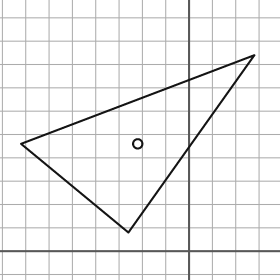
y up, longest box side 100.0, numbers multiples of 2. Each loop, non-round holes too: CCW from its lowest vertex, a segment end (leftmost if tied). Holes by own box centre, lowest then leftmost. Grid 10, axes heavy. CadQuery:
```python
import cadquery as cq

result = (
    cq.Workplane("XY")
    .moveTo(-26.0, 8.0)
    .lineTo(28.0, 84.0)
    .lineTo(-72.0, 46.0)
    .close()
    .moveTo(-22.0, 46.0)
    .circle(2.0)
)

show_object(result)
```